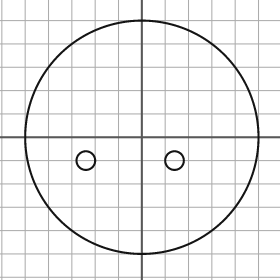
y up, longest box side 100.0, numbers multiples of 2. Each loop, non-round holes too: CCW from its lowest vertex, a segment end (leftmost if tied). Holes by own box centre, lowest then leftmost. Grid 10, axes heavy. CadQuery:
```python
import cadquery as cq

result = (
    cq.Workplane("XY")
    .moveTo(0.0, 0.0)
    .circle(50.0)
    .moveTo(-24.0, -10.0)
    .circle(4.0)
    .moveTo(14.0, -10.0)
    .circle(4.0)
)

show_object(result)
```